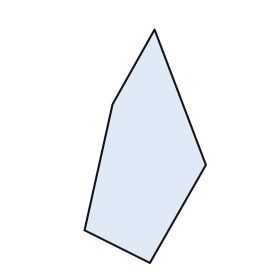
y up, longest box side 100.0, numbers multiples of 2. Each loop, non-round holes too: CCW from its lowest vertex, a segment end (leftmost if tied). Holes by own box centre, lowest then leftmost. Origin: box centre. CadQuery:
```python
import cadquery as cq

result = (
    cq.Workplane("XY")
    .moveTo(2.0, -50.0)
    .lineTo(26.0, -8.0)
    .lineTo(4.0, 50.0)
    .lineTo(-14.0, 18.0)
    .lineTo(-26.0, -36.0)
    .close()
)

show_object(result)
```